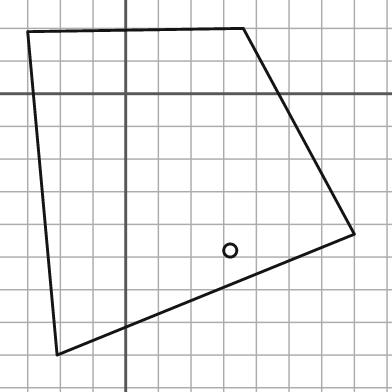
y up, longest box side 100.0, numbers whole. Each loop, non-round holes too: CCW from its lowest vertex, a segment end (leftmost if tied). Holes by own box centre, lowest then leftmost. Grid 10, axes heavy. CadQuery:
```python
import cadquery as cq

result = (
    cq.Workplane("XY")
    .moveTo(-21.0, -80.0)
    .lineTo(70.0, -43.0)
    .lineTo(36.0, 20.0)
    .lineTo(-30.0, 19.0)
    .close()
    .moveTo(32.0, -48.0)
    .circle(2.0)
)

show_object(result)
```